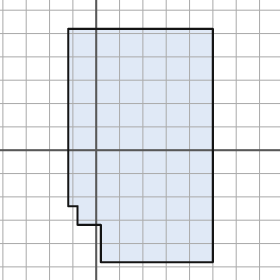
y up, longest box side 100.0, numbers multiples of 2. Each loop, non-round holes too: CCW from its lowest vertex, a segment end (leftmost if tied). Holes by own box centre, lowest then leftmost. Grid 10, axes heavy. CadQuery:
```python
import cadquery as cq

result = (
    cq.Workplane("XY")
    .moveTo(2.0, -48.0)
    .lineTo(50.0, -48.0)
    .lineTo(50.0, 52.0)
    .lineTo(-12.0, 52.0)
    .lineTo(-12.0, -24.0)
    .lineTo(-8.0, -24.0)
    .lineTo(-8.0, -32.0)
    .lineTo(2.0, -32.0)
    .close()
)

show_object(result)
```